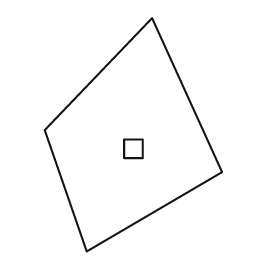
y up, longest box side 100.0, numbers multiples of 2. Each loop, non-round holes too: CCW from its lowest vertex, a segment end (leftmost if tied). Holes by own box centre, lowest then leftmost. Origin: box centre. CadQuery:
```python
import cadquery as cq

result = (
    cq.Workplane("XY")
    .moveTo(-20.0, -50.0)
    .lineTo(38.0, -16.0)
    .lineTo(8.0, 50.0)
    .lineTo(-38.0, 2.0)
    .close()
    .moveTo(-4.0, -10.0)
    .lineTo(4.0, -10.0)
    .lineTo(4.0, -2.0)
    .lineTo(-4.0, -2.0)
    .close()
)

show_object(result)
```